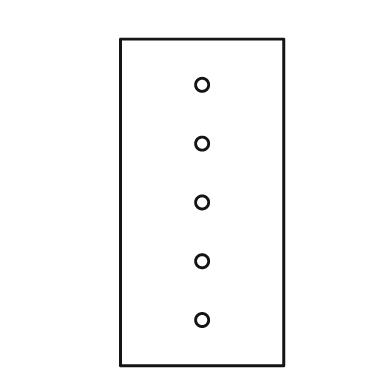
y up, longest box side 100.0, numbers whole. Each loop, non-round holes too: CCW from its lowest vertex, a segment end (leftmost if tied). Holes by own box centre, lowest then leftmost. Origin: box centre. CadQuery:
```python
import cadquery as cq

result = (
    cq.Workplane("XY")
    .moveTo(-25.0, -50.0)
    .lineTo(25.0, -50.0)
    .lineTo(25.0, 50.0)
    .lineTo(-25.0, 50.0)
    .close()
    .moveTo(0.0, -36.0)
    .circle(2.0)
    .moveTo(0.0, -18.0)
    .circle(2.0)
    .moveTo(0.0, 0.0)
    .circle(2.0)
    .moveTo(0.0, 18.0)
    .circle(2.0)
    .moveTo(0.0, 36.0)
    .circle(2.0)
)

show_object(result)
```